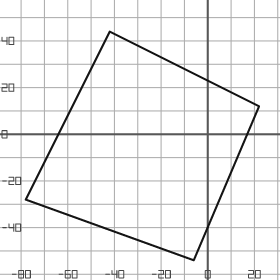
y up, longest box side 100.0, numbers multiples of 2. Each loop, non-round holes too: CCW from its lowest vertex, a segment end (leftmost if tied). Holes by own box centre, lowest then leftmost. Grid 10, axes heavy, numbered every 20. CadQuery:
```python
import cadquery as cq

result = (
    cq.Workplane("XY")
    .moveTo(-6.0, -54.0)
    .lineTo(22.0, 12.0)
    .lineTo(-42.0, 44.0)
    .lineTo(-78.0, -28.0)
    .close()
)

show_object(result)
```